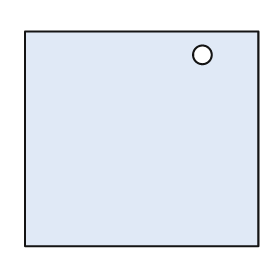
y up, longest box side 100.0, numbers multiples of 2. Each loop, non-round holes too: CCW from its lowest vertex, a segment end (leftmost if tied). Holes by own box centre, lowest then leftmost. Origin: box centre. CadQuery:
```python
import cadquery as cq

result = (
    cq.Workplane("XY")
    .moveTo(-50.0, -46.0)
    .lineTo(50.0, -46.0)
    .lineTo(50.0, 46.0)
    .lineTo(-50.0, 46.0)
    .close()
    .moveTo(26.0, 36.0)
    .circle(4.0)
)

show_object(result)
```